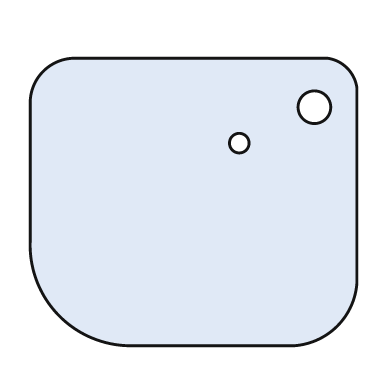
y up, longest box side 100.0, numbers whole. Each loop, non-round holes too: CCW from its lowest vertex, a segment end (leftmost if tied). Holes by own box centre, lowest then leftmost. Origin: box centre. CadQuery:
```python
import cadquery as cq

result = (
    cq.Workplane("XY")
    .moveTo(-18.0, -44.0)
    .lineTo(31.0, -44.0)
    .threePointArc((44.0, -38.0), (50.0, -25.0))
    .lineTo(50.0, 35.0)
    .threePointArc((47.0, 41.0), (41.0, 44.0))
    .lineTo(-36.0, 44.0)
    .threePointArc((-46.0, 40.0), (-50.0, 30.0))
    .lineTo(-50.0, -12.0)
    .threePointArc((-41.0, -35.0), (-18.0, -44.0))
    .close()
    .moveTo(14.0, 18.0)
    .circle(3.0)
    .moveTo(37.0, 29.0)
    .circle(5.0)
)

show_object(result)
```